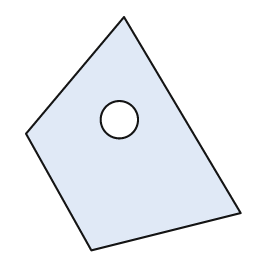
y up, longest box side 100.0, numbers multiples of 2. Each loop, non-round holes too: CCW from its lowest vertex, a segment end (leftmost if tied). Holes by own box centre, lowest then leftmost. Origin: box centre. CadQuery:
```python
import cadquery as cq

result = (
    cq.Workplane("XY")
    .moveTo(-18.0, -50.0)
    .lineTo(46.0, -34.0)
    .lineTo(-4.0, 50.0)
    .lineTo(-46.0, 0.0)
    .close()
    .moveTo(-6.0, 6.0)
    .circle(8.0)
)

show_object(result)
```